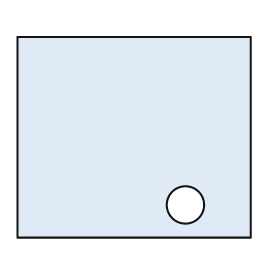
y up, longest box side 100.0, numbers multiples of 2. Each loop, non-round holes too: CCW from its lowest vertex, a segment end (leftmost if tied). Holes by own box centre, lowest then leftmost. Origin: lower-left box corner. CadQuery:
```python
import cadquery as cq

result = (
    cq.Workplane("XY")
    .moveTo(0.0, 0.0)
    .lineTo(100.0, 0.0)
    .lineTo(100.0, 86.0)
    .lineTo(0.0, 86.0)
    .close()
    .moveTo(72.0, 14.0)
    .circle(8.0)
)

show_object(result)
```